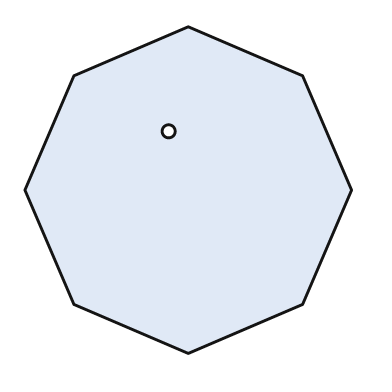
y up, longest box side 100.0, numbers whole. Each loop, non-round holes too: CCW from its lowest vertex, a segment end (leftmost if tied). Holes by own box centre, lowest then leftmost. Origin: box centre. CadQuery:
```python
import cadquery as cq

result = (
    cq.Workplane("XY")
    .moveTo(0.0, -50.0)
    .lineTo(35.0, -35.0)
    .lineTo(50.0, 0.0)
    .lineTo(35.0, 35.0)
    .lineTo(0.0, 50.0)
    .lineTo(-35.0, 35.0)
    .lineTo(-50.0, 0.0)
    .lineTo(-35.0, -35.0)
    .close()
    .moveTo(-6.0, 18.0)
    .circle(2.0)
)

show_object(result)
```